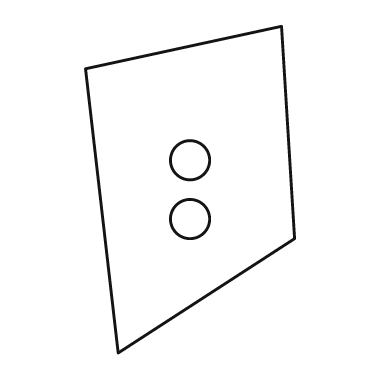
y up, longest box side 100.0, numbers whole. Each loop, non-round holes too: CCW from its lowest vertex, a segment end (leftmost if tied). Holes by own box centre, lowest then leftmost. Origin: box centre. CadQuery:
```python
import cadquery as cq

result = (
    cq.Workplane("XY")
    .moveTo(-22.0, -50.0)
    .lineTo(32.0, -15.0)
    .lineTo(28.0, 50.0)
    .lineTo(-32.0, 37.0)
    .close()
    .moveTo(0.0, -9.0)
    .circle(6.0)
    .moveTo(0.0, 9.0)
    .circle(6.0)
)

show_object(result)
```